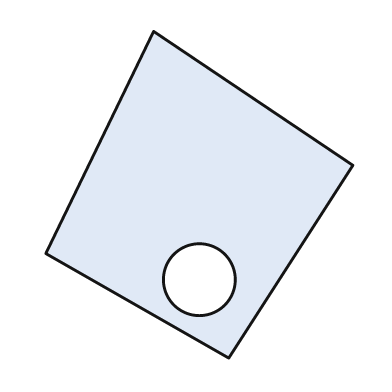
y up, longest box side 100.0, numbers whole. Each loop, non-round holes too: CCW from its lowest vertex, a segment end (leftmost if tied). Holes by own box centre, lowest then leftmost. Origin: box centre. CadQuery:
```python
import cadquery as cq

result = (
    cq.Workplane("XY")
    .moveTo(9.0, -50.0)
    .lineTo(47.0, 9.0)
    .lineTo(-14.0, 50.0)
    .lineTo(-47.0, -18.0)
    .close()
    .moveTo(0.0, -26.0)
    .circle(11.0)
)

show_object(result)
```